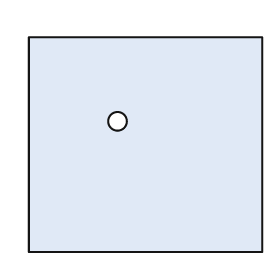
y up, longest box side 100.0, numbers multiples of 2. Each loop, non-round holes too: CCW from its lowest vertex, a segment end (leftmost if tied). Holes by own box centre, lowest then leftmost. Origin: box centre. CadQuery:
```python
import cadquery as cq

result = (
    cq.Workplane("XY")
    .moveTo(-50.0, -46.0)
    .lineTo(50.0, -46.0)
    .lineTo(50.0, 46.0)
    .lineTo(-50.0, 46.0)
    .close()
    .moveTo(-12.0, 10.0)
    .circle(4.0)
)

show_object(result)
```